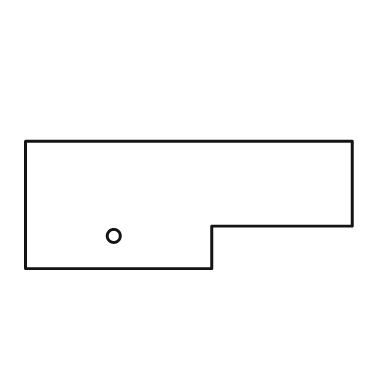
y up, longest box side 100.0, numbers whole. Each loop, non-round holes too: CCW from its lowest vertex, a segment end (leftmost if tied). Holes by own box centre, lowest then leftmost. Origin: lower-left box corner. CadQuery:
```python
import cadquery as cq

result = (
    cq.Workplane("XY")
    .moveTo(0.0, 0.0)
    .lineTo(57.0, 0.0)
    .lineTo(57.0, 13.0)
    .lineTo(100.0, 13.0)
    .lineTo(100.0, 39.0)
    .lineTo(0.0, 39.0)
    .close()
    .moveTo(27.0, 10.0)
    .circle(2.0)
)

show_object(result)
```